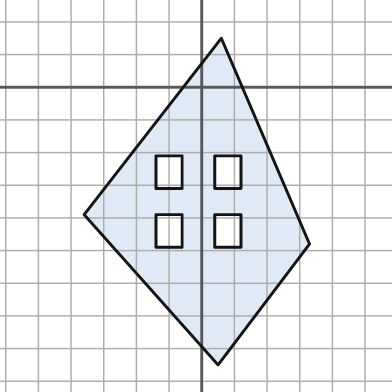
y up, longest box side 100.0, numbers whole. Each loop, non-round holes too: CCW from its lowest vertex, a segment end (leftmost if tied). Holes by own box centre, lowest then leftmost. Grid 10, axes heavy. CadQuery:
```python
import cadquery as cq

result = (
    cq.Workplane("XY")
    .moveTo(5.0, -85.0)
    .lineTo(33.0, -48.0)
    .lineTo(6.0, 15.0)
    .lineTo(-36.0, -39.0)
    .close()
    .moveTo(-14.0, -49.0)
    .lineTo(-6.0, -49.0)
    .lineTo(-6.0, -39.0)
    .lineTo(-14.0, -39.0)
    .close()
    .moveTo(4.0, -49.0)
    .lineTo(12.0, -49.0)
    .lineTo(12.0, -39.0)
    .lineTo(4.0, -39.0)
    .close()
    .moveTo(-14.0, -31.0)
    .lineTo(-6.0, -31.0)
    .lineTo(-6.0, -21.0)
    .lineTo(-14.0, -21.0)
    .close()
    .moveTo(4.0, -31.0)
    .lineTo(12.0, -31.0)
    .lineTo(12.0, -21.0)
    .lineTo(4.0, -21.0)
    .close()
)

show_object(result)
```